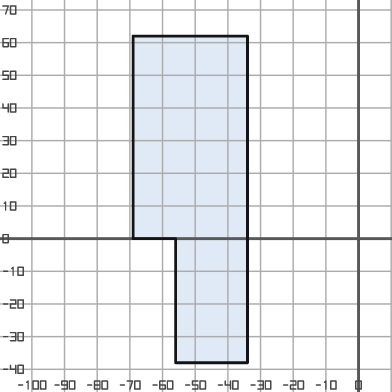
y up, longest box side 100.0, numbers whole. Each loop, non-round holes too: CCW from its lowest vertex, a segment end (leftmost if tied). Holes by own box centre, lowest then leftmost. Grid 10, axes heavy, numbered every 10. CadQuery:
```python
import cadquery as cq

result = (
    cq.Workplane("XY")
    .moveTo(-56.0, -38.0)
    .lineTo(-34.0, -38.0)
    .lineTo(-34.0, 62.0)
    .lineTo(-69.0, 62.0)
    .lineTo(-69.0, 0.0)
    .lineTo(-56.0, 0.0)
    .close()
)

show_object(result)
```